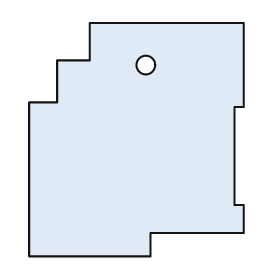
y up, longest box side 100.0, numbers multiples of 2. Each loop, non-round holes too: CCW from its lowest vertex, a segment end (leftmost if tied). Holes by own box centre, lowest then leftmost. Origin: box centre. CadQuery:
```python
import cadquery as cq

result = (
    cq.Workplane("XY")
    .moveTo(-46.0, -50.0)
    .lineTo(6.0, -50.0)
    .lineTo(6.0, -40.0)
    .lineTo(46.0, -40.0)
    .lineTo(46.0, -28.0)
    .lineTo(42.0, -28.0)
    .lineTo(42.0, 14.0)
    .lineTo(46.0, 14.0)
    .lineTo(46.0, 50.0)
    .lineTo(-20.0, 50.0)
    .lineTo(-20.0, 34.0)
    .lineTo(-34.0, 34.0)
    .lineTo(-34.0, 16.0)
    .lineTo(-46.0, 16.0)
    .close()
    .moveTo(4.0, 32.0)
    .circle(4.0)
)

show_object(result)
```